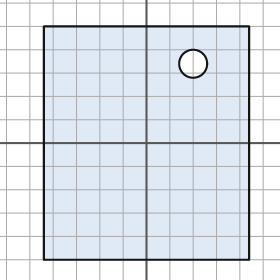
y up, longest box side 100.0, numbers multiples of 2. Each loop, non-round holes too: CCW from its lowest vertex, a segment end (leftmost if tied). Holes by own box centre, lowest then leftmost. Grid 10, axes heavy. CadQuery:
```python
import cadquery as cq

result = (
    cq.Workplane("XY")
    .moveTo(-44.0, -50.0)
    .lineTo(44.0, -50.0)
    .lineTo(44.0, 50.0)
    .lineTo(-44.0, 50.0)
    .close()
    .moveTo(20.0, 34.0)
    .circle(6.0)
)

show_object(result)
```